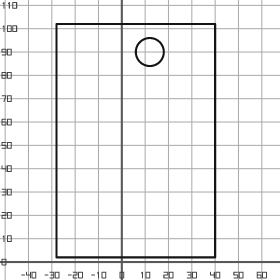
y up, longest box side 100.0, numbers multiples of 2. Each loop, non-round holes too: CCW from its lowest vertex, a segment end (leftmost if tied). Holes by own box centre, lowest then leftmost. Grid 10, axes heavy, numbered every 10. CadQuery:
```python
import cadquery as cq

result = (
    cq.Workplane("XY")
    .moveTo(-28.0, 2.0)
    .lineTo(40.0, 2.0)
    .lineTo(40.0, 102.0)
    .lineTo(-28.0, 102.0)
    .close()
    .moveTo(12.0, 90.0)
    .circle(6.0)
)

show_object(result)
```